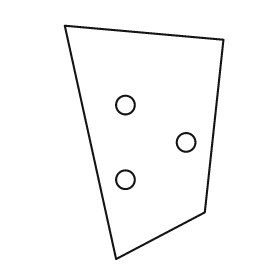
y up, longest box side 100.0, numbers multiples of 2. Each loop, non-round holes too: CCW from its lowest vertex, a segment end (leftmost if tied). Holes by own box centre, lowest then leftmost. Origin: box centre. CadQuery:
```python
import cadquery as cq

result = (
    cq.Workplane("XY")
    .moveTo(-12.0, -50.0)
    .lineTo(26.0, -30.0)
    .lineTo(34.0, 44.0)
    .lineTo(-34.0, 50.0)
    .close()
    .moveTo(-8.0, -16.0)
    .circle(4.0)
    .moveTo(18.0, 0.0)
    .circle(4.0)
    .moveTo(-8.0, 16.0)
    .circle(4.0)
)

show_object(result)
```